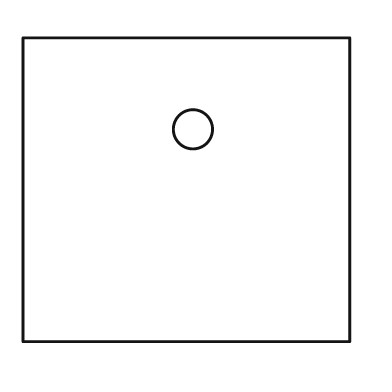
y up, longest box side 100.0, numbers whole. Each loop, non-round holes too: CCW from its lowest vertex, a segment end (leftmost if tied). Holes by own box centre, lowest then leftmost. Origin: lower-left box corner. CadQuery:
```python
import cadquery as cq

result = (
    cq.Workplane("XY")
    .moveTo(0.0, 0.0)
    .lineTo(100.0, 0.0)
    .lineTo(100.0, 93.0)
    .lineTo(0.0, 93.0)
    .close()
    .moveTo(52.0, 65.0)
    .circle(6.0)
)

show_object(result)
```